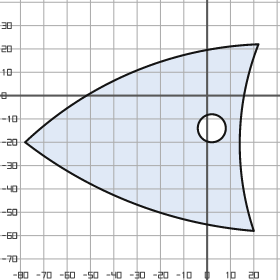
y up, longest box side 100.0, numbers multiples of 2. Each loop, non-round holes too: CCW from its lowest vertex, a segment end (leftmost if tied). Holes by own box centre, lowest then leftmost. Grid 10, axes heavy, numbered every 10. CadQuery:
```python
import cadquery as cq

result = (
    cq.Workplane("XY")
    .moveTo(20.0, -58.0)
    .threePointArc((14.0, -18.0), (22.0, 22.0))
    .threePointArc((-32.0, 10.0), (-78.0, -20.0))
    .threePointArc((-32.0, -46.0), (20.0, -58.0))
    .close()
    .moveTo(2.0, -14.0)
    .circle(6.0)
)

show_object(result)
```